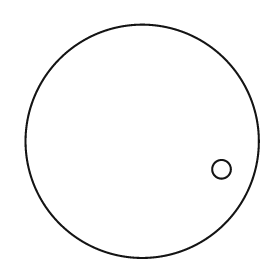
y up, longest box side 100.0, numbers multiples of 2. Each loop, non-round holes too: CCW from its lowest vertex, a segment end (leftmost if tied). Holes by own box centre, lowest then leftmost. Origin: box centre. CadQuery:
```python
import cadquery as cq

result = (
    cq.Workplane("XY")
    .moveTo(0.0, 0.0)
    .circle(50.0)
    .moveTo(34.0, -12.0)
    .circle(4.0)
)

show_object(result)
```